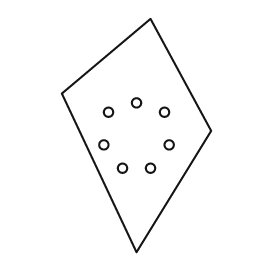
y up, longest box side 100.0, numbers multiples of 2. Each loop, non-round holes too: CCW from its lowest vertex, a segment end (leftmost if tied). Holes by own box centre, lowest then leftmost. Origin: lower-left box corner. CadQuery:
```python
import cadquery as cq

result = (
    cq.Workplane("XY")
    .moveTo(32.0, 0.0)
    .lineTo(64.0, 52.0)
    .lineTo(38.0, 100.0)
    .lineTo(0.0, 68.0)
    .close()
    .moveTo(26.0, 36.0)
    .circle(2.0)
    .moveTo(38.0, 36.0)
    .circle(2.0)
    .moveTo(18.0, 46.0)
    .circle(2.0)
    .moveTo(46.0, 46.0)
    .circle(2.0)
    .moveTo(20.0, 60.0)
    .circle(2.0)
    .moveTo(44.0, 60.0)
    .circle(2.0)
    .moveTo(32.0, 64.0)
    .circle(2.0)
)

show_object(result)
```